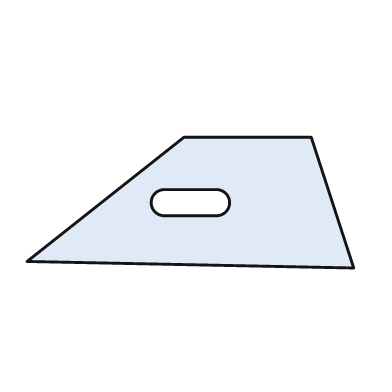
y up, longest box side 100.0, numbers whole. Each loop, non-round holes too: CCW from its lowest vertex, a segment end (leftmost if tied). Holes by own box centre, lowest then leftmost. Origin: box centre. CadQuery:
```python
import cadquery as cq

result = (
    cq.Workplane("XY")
    .moveTo(50.0, -20.0)
    .lineTo(37.0, 20.0)
    .lineTo(-2.0, 20.0)
    .lineTo(-50.0, -18.0)
    .close()
    .moveTo(-8.0, -4.0)
    .lineTo(8.0, -4.0)
    .threePointArc((12.0, 0.0), (8.0, 4.0))
    .lineTo(-8.0, 4.0)
    .threePointArc((-12.0, 0.0), (-8.0, -4.0))
    .close()
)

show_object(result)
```